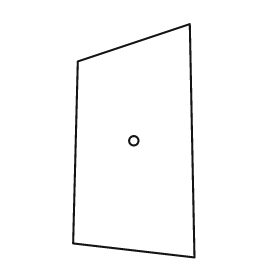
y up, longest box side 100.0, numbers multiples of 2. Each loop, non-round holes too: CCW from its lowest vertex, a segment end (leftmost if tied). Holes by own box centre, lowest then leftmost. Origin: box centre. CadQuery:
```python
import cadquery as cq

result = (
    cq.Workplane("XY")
    .moveTo(26.0, -50.0)
    .lineTo(24.0, 50.0)
    .lineTo(-24.0, 34.0)
    .lineTo(-26.0, -44.0)
    .close()
    .moveTo(0.0, 0.0)
    .circle(2.0)
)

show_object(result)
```